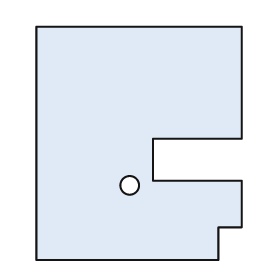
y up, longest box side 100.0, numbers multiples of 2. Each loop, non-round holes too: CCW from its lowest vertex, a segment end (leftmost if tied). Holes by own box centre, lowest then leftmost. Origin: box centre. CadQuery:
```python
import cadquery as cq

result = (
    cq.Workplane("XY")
    .moveTo(-44.0, -50.0)
    .lineTo(34.0, -50.0)
    .lineTo(34.0, -36.0)
    .lineTo(44.0, -36.0)
    .lineTo(44.0, -16.0)
    .lineTo(6.0, -16.0)
    .lineTo(6.0, 2.0)
    .lineTo(44.0, 2.0)
    .lineTo(44.0, 50.0)
    .lineTo(-44.0, 50.0)
    .close()
    .moveTo(-4.0, -18.0)
    .circle(4.0)
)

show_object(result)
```